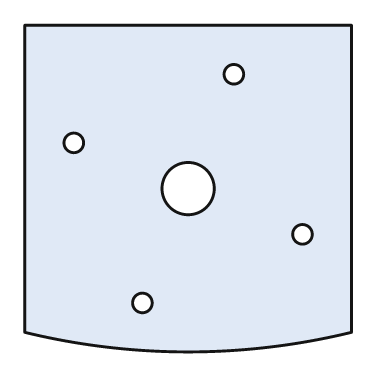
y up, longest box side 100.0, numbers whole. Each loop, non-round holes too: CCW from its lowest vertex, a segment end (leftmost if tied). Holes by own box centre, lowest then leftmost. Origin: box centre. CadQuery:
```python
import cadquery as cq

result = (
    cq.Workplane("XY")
    .moveTo(-50.0, -44.0)
    .threePointArc((0.0, -50.0), (50.0, -44.0))
    .lineTo(50.0, 50.0)
    .lineTo(-50.0, 50.0)
    .close()
    .moveTo(-14.0, -35.0)
    .circle(3.0)
    .moveTo(35.0, -14.0)
    .circle(3.0)
    .moveTo(0.0, 0.0)
    .circle(8.0)
    .moveTo(-35.0, 14.0)
    .circle(3.0)
    .moveTo(14.0, 35.0)
    .circle(3.0)
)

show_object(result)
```